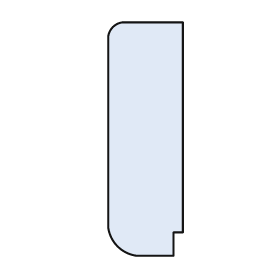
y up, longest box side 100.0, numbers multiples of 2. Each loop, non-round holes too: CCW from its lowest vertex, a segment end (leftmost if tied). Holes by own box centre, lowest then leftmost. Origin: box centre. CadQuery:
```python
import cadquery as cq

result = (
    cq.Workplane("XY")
    .moveTo(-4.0, -50.0)
    .lineTo(12.0, -50.0)
    .lineTo(12.0, -40.0)
    .lineTo(16.0, -40.0)
    .lineTo(16.0, 50.0)
    .lineTo(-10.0, 50.0)
    .threePointArc((-14.0, 48.0), (-16.0, 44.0))
    .lineTo(-16.0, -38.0)
    .threePointArc((-12.0, -46.0), (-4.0, -50.0))
    .close()
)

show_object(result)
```